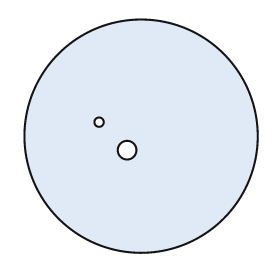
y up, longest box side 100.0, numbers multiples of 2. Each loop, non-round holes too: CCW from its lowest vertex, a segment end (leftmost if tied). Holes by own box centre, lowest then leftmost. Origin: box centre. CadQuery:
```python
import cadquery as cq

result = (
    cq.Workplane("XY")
    .moveTo(0.0, 0.0)
    .circle(50.0)
    .moveTo(-6.0, -6.0)
    .circle(4.0)
    .moveTo(-18.0, 6.0)
    .circle(2.0)
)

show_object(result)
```